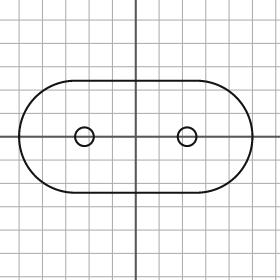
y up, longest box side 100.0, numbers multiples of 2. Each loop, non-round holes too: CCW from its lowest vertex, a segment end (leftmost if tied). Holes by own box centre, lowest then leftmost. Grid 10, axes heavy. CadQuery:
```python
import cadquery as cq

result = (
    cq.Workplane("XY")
    .moveTo(-26.0, -24.0)
    .lineTo(26.0, -24.0)
    .threePointArc((50.0, 0.0), (26.0, 24.0))
    .lineTo(-26.0, 24.0)
    .threePointArc((-50.0, 0.0), (-26.0, -24.0))
    .close()
    .moveTo(-22.0, 0.0)
    .circle(4.0)
    .moveTo(22.0, 0.0)
    .circle(4.0)
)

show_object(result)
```